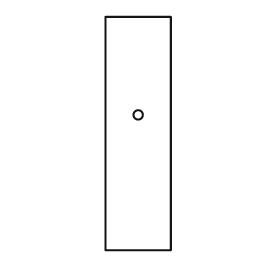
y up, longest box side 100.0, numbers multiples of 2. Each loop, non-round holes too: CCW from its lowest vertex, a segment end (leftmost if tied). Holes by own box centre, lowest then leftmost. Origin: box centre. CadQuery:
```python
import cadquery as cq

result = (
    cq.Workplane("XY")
    .moveTo(-14.0, -50.0)
    .lineTo(14.0, -50.0)
    .lineTo(14.0, 50.0)
    .lineTo(-14.0, 50.0)
    .close()
    .moveTo(0.0, 8.0)
    .circle(2.0)
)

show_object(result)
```